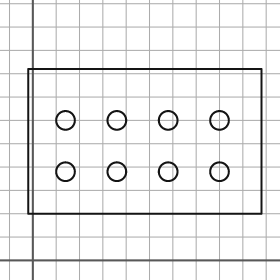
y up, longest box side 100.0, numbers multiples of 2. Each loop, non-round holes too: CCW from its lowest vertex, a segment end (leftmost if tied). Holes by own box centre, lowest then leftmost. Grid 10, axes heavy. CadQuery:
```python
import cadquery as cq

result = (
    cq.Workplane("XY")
    .moveTo(-2.0, 20.0)
    .lineTo(98.0, 20.0)
    .lineTo(98.0, 82.0)
    .lineTo(-2.0, 82.0)
    .close()
    .moveTo(14.0, 38.0)
    .circle(4.0)
    .moveTo(36.0, 38.0)
    .circle(4.0)
    .moveTo(58.0, 38.0)
    .circle(4.0)
    .moveTo(80.0, 38.0)
    .circle(4.0)
    .moveTo(14.0, 60.0)
    .circle(4.0)
    .moveTo(36.0, 60.0)
    .circle(4.0)
    .moveTo(58.0, 60.0)
    .circle(4.0)
    .moveTo(80.0, 60.0)
    .circle(4.0)
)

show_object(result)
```